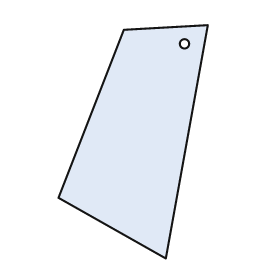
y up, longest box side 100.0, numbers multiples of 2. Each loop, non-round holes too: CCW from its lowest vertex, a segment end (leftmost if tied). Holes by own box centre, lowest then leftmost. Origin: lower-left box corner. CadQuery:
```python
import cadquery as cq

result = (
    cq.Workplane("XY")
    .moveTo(46.0, 0.0)
    .lineTo(64.0, 100.0)
    .lineTo(28.0, 98.0)
    .lineTo(0.0, 26.0)
    .close()
    .moveTo(54.0, 92.0)
    .circle(2.0)
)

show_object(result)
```